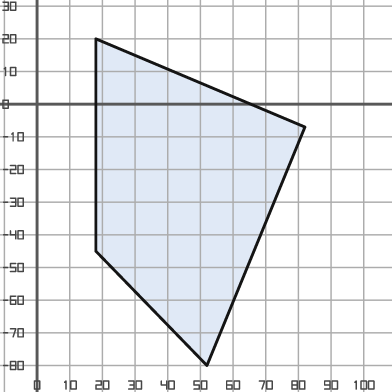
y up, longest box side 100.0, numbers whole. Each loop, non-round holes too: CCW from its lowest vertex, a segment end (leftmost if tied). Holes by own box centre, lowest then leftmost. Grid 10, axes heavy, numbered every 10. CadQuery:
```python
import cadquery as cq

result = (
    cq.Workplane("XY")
    .moveTo(52.0, -80.0)
    .lineTo(82.0, -7.0)
    .lineTo(18.0, 20.0)
    .lineTo(18.0, -45.0)
    .close()
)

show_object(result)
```